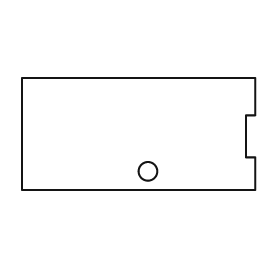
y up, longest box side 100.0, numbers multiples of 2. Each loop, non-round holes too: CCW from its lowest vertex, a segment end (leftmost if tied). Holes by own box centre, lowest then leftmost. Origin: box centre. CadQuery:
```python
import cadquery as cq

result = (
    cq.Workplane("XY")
    .moveTo(-50.0, -24.0)
    .lineTo(50.0, -24.0)
    .lineTo(50.0, -10.0)
    .lineTo(46.0, -10.0)
    .lineTo(46.0, 8.0)
    .lineTo(50.0, 8.0)
    .lineTo(50.0, 24.0)
    .lineTo(-50.0, 24.0)
    .close()
    .moveTo(4.0, -16.0)
    .circle(4.0)
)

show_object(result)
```